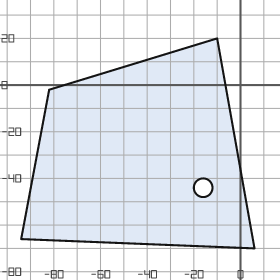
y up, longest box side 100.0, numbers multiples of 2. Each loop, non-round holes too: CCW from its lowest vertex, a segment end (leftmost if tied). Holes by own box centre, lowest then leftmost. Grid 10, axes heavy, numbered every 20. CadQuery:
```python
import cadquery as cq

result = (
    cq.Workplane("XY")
    .moveTo(6.0, -70.0)
    .lineTo(-10.0, 20.0)
    .lineTo(-82.0, -2.0)
    .lineTo(-94.0, -66.0)
    .close()
    .moveTo(-16.0, -44.0)
    .circle(4.0)
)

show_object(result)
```